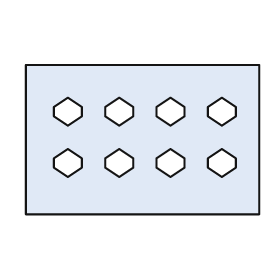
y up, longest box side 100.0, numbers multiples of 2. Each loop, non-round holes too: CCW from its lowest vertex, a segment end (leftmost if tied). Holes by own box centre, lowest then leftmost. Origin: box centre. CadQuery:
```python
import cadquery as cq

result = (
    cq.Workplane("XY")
    .moveTo(-50.0, -32.0)
    .lineTo(50.0, -32.0)
    .lineTo(50.0, 32.0)
    .lineTo(-50.0, 32.0)
    .close()
    .moveTo(-32.0, -16.0)
    .lineTo(-26.0, -12.0)
    .lineTo(-26.0, -8.0)
    .lineTo(-32.0, -4.0)
    .lineTo(-38.0, -8.0)
    .lineTo(-38.0, -12.0)
    .close()
    .moveTo(-10.0, -16.0)
    .lineTo(-4.0, -12.0)
    .lineTo(-4.0, -8.0)
    .lineTo(-10.0, -4.0)
    .lineTo(-16.0, -8.0)
    .lineTo(-16.0, -12.0)
    .close()
    .moveTo(12.0, -16.0)
    .lineTo(18.0, -12.0)
    .lineTo(18.0, -8.0)
    .lineTo(12.0, -4.0)
    .lineTo(6.0, -8.0)
    .lineTo(6.0, -12.0)
    .close()
    .moveTo(34.0, -16.0)
    .lineTo(40.0, -12.0)
    .lineTo(40.0, -8.0)
    .lineTo(34.0, -4.0)
    .lineTo(28.0, -8.0)
    .lineTo(28.0, -12.0)
    .close()
    .moveTo(-32.0, 6.0)
    .lineTo(-26.0, 10.0)
    .lineTo(-26.0, 14.0)
    .lineTo(-32.0, 18.0)
    .lineTo(-38.0, 14.0)
    .lineTo(-38.0, 10.0)
    .close()
    .moveTo(-10.0, 6.0)
    .lineTo(-4.0, 10.0)
    .lineTo(-4.0, 14.0)
    .lineTo(-10.0, 18.0)
    .lineTo(-16.0, 14.0)
    .lineTo(-16.0, 10.0)
    .close()
    .moveTo(12.0, 6.0)
    .lineTo(18.0, 10.0)
    .lineTo(18.0, 14.0)
    .lineTo(12.0, 18.0)
    .lineTo(6.0, 14.0)
    .lineTo(6.0, 10.0)
    .close()
    .moveTo(34.0, 6.0)
    .lineTo(40.0, 10.0)
    .lineTo(40.0, 14.0)
    .lineTo(34.0, 18.0)
    .lineTo(28.0, 14.0)
    .lineTo(28.0, 10.0)
    .close()
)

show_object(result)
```